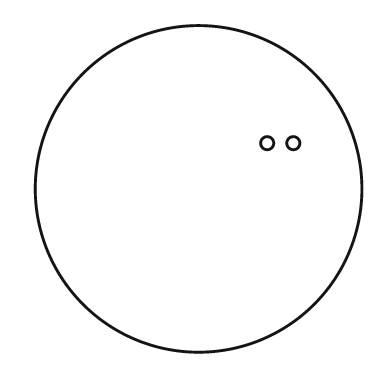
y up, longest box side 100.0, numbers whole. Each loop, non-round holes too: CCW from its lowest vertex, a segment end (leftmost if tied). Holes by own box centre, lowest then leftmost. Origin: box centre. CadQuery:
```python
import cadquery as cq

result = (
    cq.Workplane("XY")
    .moveTo(0.0, 0.0)
    .circle(50.0)
    .moveTo(21.0, 14.0)
    .circle(2.0)
    .moveTo(29.0, 14.0)
    .circle(2.0)
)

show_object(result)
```